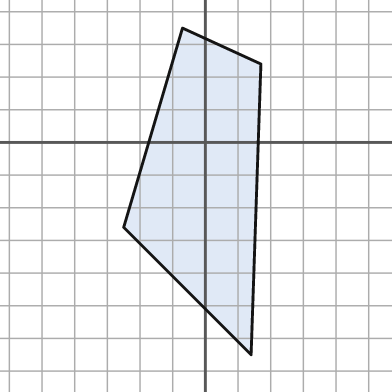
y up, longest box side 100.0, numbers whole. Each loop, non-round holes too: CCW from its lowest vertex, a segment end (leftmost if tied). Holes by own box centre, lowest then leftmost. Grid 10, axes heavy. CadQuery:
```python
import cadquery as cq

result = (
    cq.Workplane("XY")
    .moveTo(14.0, -65.0)
    .lineTo(17.0, 24.0)
    .lineTo(-7.0, 35.0)
    .lineTo(-25.0, -26.0)
    .close()
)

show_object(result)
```